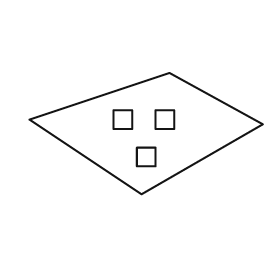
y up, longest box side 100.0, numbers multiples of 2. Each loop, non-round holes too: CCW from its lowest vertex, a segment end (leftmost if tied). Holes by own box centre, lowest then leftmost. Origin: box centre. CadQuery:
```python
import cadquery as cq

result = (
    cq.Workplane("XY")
    .moveTo(-2.0, -26.0)
    .lineTo(50.0, 4.0)
    .lineTo(10.0, 26.0)
    .lineTo(-50.0, 6.0)
    .close()
    .moveTo(-4.0, -14.0)
    .lineTo(4.0, -14.0)
    .lineTo(4.0, -6.0)
    .lineTo(-4.0, -6.0)
    .close()
    .moveTo(-14.0, 2.0)
    .lineTo(-6.0, 2.0)
    .lineTo(-6.0, 10.0)
    .lineTo(-14.0, 10.0)
    .close()
    .moveTo(4.0, 2.0)
    .lineTo(12.0, 2.0)
    .lineTo(12.0, 10.0)
    .lineTo(4.0, 10.0)
    .close()
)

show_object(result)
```